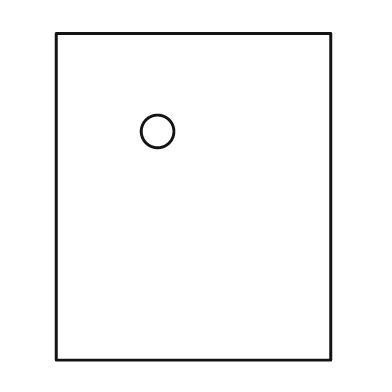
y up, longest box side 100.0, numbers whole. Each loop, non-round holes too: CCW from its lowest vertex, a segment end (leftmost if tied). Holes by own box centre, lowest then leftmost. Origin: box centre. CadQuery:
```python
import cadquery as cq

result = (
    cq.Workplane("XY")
    .moveTo(-42.0, -50.0)
    .lineTo(42.0, -50.0)
    .lineTo(42.0, 50.0)
    .lineTo(-42.0, 50.0)
    .close()
    .moveTo(-11.0, 20.0)
    .circle(5.0)
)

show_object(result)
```